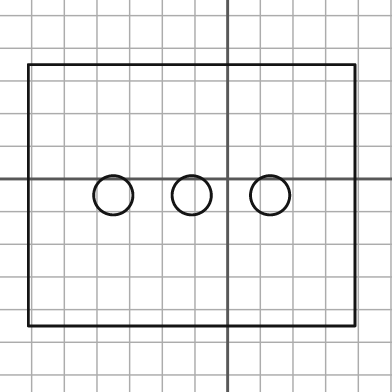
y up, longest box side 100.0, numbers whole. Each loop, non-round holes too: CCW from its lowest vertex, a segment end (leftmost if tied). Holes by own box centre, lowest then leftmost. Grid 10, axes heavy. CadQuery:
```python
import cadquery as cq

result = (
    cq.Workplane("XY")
    .moveTo(-61.0, -45.0)
    .lineTo(39.0, -45.0)
    .lineTo(39.0, 35.0)
    .lineTo(-61.0, 35.0)
    .close()
    .moveTo(-35.0, -5.0)
    .circle(6.0)
    .moveTo(-11.0, -5.0)
    .circle(6.0)
    .moveTo(13.0, -5.0)
    .circle(6.0)
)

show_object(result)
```